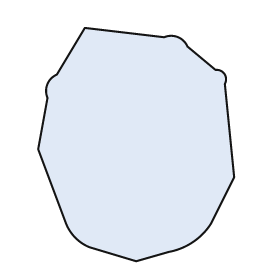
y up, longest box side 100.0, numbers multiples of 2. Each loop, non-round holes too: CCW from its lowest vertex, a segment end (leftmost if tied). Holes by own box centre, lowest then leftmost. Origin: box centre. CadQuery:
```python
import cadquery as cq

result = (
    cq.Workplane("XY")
    .moveTo(0.0, -50.0)
    .lineTo(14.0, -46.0)
    .threePointArc((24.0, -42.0), (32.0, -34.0))
    .lineTo(42.0, -14.0)
    .lineTo(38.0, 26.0)
    .threePointArc((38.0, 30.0), (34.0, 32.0))
    .lineTo(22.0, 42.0)
    .threePointArc((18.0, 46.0), (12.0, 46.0))
    .lineTo(-22.0, 50.0)
    .lineTo(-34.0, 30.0)
    .threePointArc((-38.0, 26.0), (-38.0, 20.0))
    .lineTo(-42.0, -2.0)
    .lineTo(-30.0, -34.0)
    .threePointArc((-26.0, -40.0), (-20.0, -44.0))
    .close()
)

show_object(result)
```